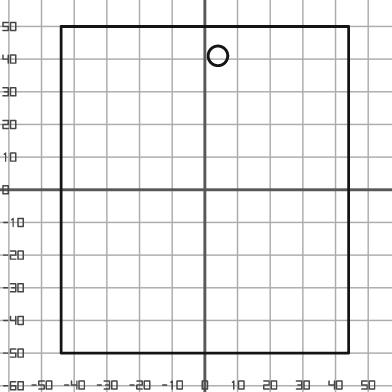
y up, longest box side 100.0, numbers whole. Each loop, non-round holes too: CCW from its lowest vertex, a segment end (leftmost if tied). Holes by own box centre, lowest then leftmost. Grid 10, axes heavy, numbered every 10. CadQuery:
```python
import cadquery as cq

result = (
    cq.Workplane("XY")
    .moveTo(-44.0, -50.0)
    .lineTo(44.0, -50.0)
    .lineTo(44.0, 50.0)
    .lineTo(-44.0, 50.0)
    .close()
    .moveTo(4.0, 41.0)
    .circle(3.0)
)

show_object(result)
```